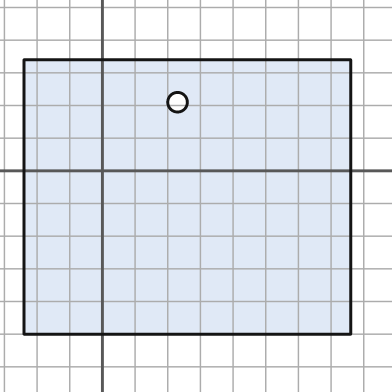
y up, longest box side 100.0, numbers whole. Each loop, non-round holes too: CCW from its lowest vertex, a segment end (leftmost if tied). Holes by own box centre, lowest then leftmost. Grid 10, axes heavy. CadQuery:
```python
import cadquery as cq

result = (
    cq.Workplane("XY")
    .moveTo(-24.0, -50.0)
    .lineTo(76.0, -50.0)
    .lineTo(76.0, 34.0)
    .lineTo(-24.0, 34.0)
    .close()
    .moveTo(23.0, 21.0)
    .circle(3.0)
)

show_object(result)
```